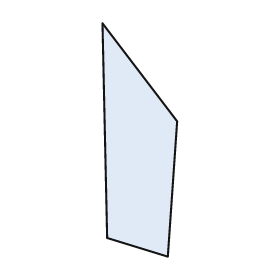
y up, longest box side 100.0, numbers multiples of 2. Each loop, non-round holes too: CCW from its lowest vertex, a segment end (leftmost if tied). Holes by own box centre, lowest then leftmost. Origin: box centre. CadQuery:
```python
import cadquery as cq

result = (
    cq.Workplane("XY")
    .moveTo(12.0, -50.0)
    .lineTo(16.0, 8.0)
    .lineTo(-16.0, 50.0)
    .lineTo(-14.0, -42.0)
    .close()
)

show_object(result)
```